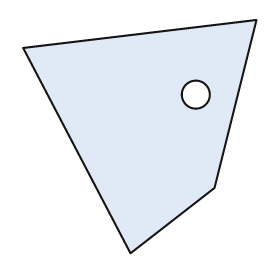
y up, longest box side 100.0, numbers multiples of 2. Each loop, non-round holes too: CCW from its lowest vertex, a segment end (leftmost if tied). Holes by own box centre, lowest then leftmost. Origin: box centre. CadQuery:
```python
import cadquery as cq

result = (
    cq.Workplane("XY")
    .moveTo(-4.0, -50.0)
    .lineTo(32.0, -22.0)
    .lineTo(50.0, 50.0)
    .lineTo(-50.0, 38.0)
    .close()
    .moveTo(24.0, 18.0)
    .circle(6.0)
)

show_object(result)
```